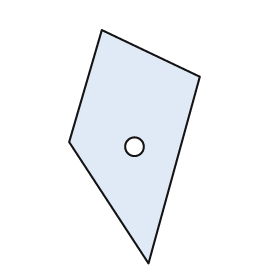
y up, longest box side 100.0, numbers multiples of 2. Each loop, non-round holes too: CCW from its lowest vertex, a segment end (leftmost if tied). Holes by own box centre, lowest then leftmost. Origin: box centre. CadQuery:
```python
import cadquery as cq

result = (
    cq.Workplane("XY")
    .moveTo(6.0, -50.0)
    .lineTo(28.0, 30.0)
    .lineTo(-14.0, 50.0)
    .lineTo(-28.0, 2.0)
    .close()
    .moveTo(0.0, 0.0)
    .circle(4.0)
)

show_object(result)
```